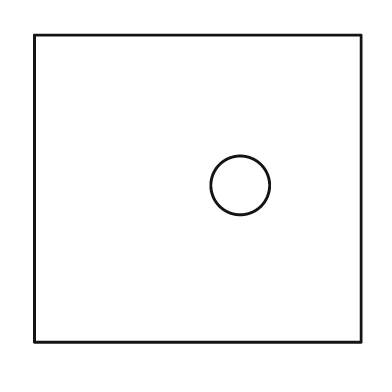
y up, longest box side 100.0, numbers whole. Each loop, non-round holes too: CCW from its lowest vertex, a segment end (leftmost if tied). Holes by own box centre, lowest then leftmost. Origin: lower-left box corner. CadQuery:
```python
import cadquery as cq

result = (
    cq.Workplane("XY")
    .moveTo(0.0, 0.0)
    .lineTo(100.0, 0.0)
    .lineTo(100.0, 94.0)
    .lineTo(0.0, 94.0)
    .close()
    .moveTo(63.0, 48.0)
    .circle(9.0)
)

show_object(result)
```